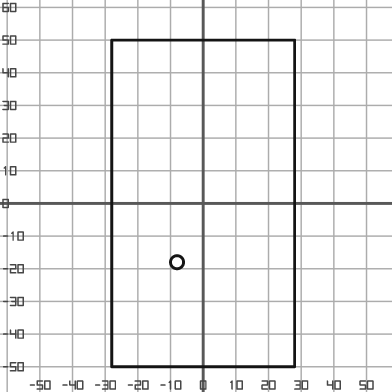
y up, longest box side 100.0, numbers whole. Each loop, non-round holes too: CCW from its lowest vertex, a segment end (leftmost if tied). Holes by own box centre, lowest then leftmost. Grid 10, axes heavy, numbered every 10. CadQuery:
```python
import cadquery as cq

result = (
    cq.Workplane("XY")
    .moveTo(-28.0, -50.0)
    .lineTo(28.0, -50.0)
    .lineTo(28.0, 50.0)
    .lineTo(-28.0, 50.0)
    .close()
    .moveTo(-8.0, -18.0)
    .circle(2.0)
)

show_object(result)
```